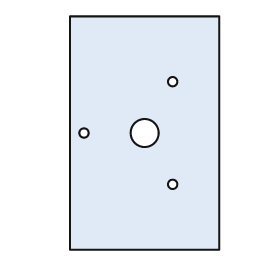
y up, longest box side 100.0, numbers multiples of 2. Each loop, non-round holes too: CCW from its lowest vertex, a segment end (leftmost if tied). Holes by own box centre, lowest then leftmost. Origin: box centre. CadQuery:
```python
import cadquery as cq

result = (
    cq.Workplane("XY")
    .moveTo(-32.0, -50.0)
    .lineTo(32.0, -50.0)
    .lineTo(32.0, 50.0)
    .lineTo(-32.0, 50.0)
    .close()
    .moveTo(12.0, -22.0)
    .circle(2.0)
    .moveTo(-26.0, 0.0)
    .circle(2.0)
    .moveTo(0.0, 0.0)
    .circle(6.0)
    .moveTo(12.0, 22.0)
    .circle(2.0)
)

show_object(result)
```